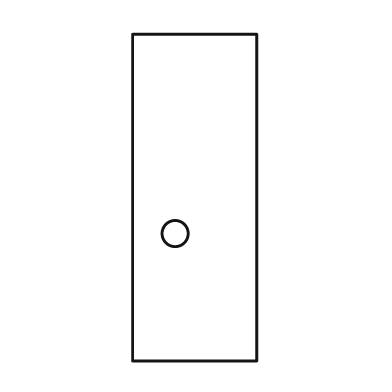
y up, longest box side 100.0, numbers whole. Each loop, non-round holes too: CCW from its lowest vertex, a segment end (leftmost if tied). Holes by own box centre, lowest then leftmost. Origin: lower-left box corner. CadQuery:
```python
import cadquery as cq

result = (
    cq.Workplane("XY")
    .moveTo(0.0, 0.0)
    .lineTo(38.0, 0.0)
    .lineTo(38.0, 100.0)
    .lineTo(0.0, 100.0)
    .close()
    .moveTo(13.0, 39.0)
    .circle(4.0)
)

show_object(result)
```